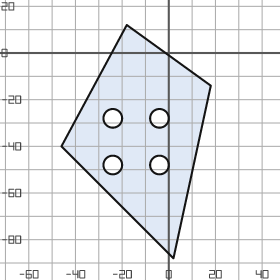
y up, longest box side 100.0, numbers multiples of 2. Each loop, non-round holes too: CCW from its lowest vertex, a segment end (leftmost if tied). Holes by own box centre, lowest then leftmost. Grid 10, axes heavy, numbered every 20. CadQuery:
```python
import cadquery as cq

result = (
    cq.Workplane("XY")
    .moveTo(2.0, -88.0)
    .lineTo(18.0, -14.0)
    .lineTo(-18.0, 12.0)
    .lineTo(-46.0, -40.0)
    .close()
    .moveTo(-24.0, -48.0)
    .circle(4.0)
    .moveTo(-4.0, -48.0)
    .circle(4.0)
    .moveTo(-24.0, -28.0)
    .circle(4.0)
    .moveTo(-4.0, -28.0)
    .circle(4.0)
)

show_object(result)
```